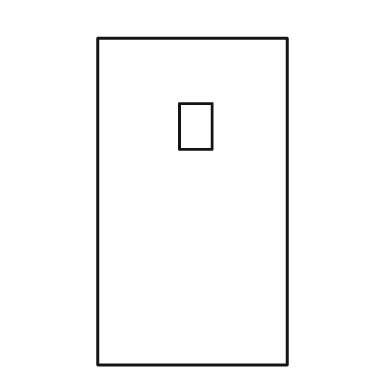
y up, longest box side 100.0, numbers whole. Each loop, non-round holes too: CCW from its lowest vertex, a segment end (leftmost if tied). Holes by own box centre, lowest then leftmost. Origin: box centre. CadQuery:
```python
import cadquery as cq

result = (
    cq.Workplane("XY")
    .moveTo(-29.0, -50.0)
    .lineTo(29.0, -50.0)
    .lineTo(29.0, 50.0)
    .lineTo(-29.0, 50.0)
    .close()
    .moveTo(-4.0, 16.0)
    .lineTo(6.0, 16.0)
    .lineTo(6.0, 30.0)
    .lineTo(-4.0, 30.0)
    .close()
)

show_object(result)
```